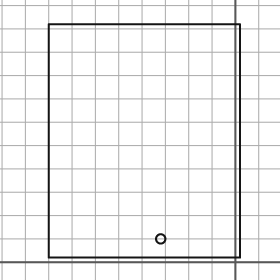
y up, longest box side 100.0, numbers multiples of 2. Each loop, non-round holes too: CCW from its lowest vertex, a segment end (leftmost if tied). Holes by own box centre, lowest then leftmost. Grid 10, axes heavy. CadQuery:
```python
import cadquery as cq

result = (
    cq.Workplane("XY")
    .moveTo(-80.0, 2.0)
    .lineTo(2.0, 2.0)
    .lineTo(2.0, 102.0)
    .lineTo(-80.0, 102.0)
    .close()
    .moveTo(-32.0, 10.0)
    .circle(2.0)
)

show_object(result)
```